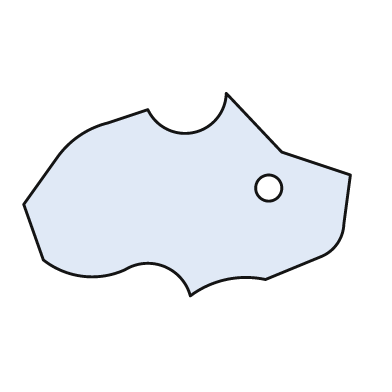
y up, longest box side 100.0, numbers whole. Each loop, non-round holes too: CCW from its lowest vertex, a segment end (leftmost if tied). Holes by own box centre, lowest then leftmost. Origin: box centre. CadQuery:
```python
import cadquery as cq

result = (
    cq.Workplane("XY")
    .moveTo(1.0, -31.0)
    .threePointArc((12.0, -26.0), (24.0, -26.0))
    .lineTo(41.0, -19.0)
    .threePointArc((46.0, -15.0), (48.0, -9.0))
    .lineTo(50.0, 6.0)
    .lineTo(29.0, 13.0)
    .lineTo(12.0, 31.0)
    .threePointArc((2.0, 19.0), (-12.0, 26.0))
    .lineTo(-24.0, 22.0)
    .threePointArc((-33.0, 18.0), (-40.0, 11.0))
    .lineTo(-50.0, -3.0)
    .lineTo(-44.0, -20.0)
    .threePointArc((-32.0, -25.0), (-19.0, -23.0))
    .threePointArc((-7.0, -22.0), (1.0, -31.0))
    .close()
    .moveTo(25.0, 2.0)
    .circle(4.0)
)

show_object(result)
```